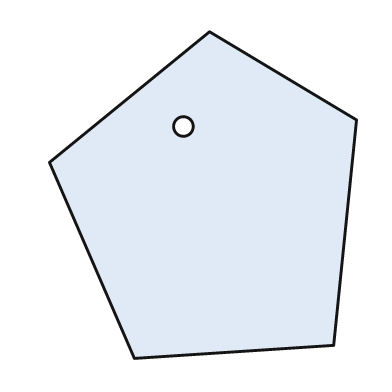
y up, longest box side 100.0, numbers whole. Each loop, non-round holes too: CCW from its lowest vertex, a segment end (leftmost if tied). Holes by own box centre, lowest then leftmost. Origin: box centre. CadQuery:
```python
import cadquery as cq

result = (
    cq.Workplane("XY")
    .moveTo(-21.0, -50.0)
    .lineTo(40.0, -46.0)
    .lineTo(47.0, 23.0)
    .lineTo(2.0, 50.0)
    .lineTo(-47.0, 10.0)
    .close()
    .moveTo(-6.0, 21.0)
    .circle(3.0)
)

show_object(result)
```